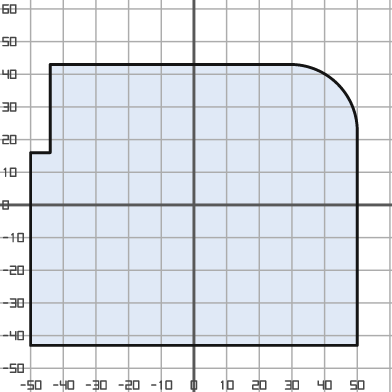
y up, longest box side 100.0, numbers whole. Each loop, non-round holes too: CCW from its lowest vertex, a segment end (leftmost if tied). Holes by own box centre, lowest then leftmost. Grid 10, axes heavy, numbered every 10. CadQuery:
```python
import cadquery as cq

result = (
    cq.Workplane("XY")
    .moveTo(-50.0, -43.0)
    .lineTo(50.0, -43.0)
    .lineTo(50.0, 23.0)
    .threePointArc((44.0, 37.0), (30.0, 43.0))
    .lineTo(-44.0, 43.0)
    .lineTo(-44.0, 16.0)
    .lineTo(-50.0, 16.0)
    .close()
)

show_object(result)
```